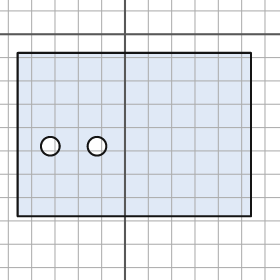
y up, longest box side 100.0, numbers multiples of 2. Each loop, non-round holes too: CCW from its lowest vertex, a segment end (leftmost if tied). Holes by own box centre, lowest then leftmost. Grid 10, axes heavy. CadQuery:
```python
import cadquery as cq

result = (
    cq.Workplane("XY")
    .moveTo(-46.0, -78.0)
    .lineTo(54.0, -78.0)
    .lineTo(54.0, -8.0)
    .lineTo(-46.0, -8.0)
    .close()
    .moveTo(-32.0, -48.0)
    .circle(4.0)
    .moveTo(-12.0, -48.0)
    .circle(4.0)
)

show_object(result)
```